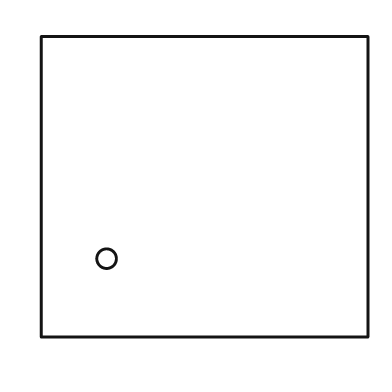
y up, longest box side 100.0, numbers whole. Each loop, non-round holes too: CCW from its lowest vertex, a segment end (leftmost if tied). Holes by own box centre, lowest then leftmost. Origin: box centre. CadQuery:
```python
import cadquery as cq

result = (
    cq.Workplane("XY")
    .moveTo(-50.0, -46.0)
    .lineTo(50.0, -46.0)
    .lineTo(50.0, 46.0)
    .lineTo(-50.0, 46.0)
    .close()
    .moveTo(-30.0, -22.0)
    .circle(3.0)
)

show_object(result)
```